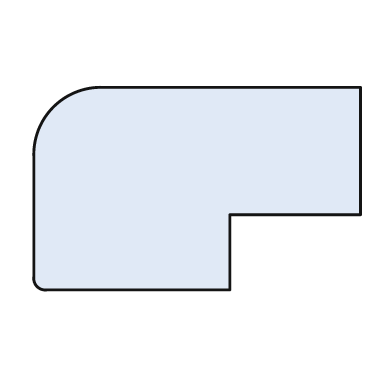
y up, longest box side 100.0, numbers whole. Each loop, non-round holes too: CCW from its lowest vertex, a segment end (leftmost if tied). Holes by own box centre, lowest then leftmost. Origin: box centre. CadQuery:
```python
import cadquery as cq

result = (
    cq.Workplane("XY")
    .moveTo(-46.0, -31.0)
    .lineTo(10.0, -31.0)
    .lineTo(10.0, -8.0)
    .lineTo(50.0, -8.0)
    .lineTo(50.0, 31.0)
    .lineTo(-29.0, 31.0)
    .threePointArc((-44.0, 25.0), (-50.0, 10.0))
    .lineTo(-50.0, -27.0)
    .threePointArc((-49.0, -30.0), (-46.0, -31.0))
    .close()
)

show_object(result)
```